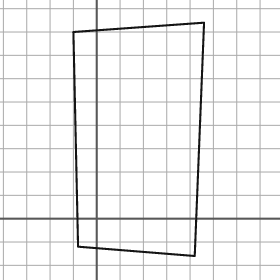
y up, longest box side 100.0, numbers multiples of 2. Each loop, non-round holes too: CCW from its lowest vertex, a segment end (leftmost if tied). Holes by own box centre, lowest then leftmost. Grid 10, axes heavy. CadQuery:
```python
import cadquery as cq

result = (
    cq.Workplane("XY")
    .moveTo(42.0, -16.0)
    .lineTo(46.0, 84.0)
    .lineTo(-10.0, 80.0)
    .lineTo(-8.0, -12.0)
    .close()
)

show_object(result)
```